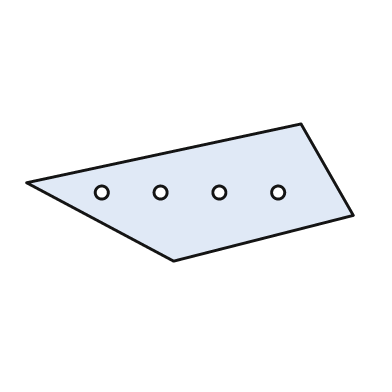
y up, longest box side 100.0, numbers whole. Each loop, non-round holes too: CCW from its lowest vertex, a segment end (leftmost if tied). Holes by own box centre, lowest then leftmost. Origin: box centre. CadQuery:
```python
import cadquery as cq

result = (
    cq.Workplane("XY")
    .moveTo(-5.0, -21.0)
    .lineTo(50.0, -7.0)
    .lineTo(34.0, 21.0)
    .lineTo(-50.0, 3.0)
    .close()
    .moveTo(-27.0, 0.0)
    .circle(2.0)
    .moveTo(-9.0, 0.0)
    .circle(2.0)
    .moveTo(9.0, 0.0)
    .circle(2.0)
    .moveTo(27.0, 0.0)
    .circle(2.0)
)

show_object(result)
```